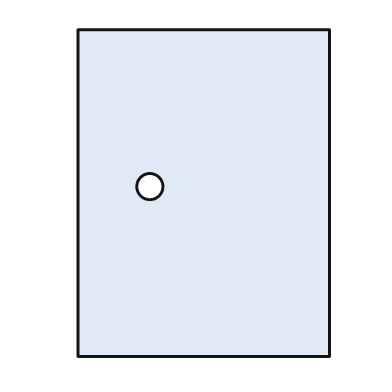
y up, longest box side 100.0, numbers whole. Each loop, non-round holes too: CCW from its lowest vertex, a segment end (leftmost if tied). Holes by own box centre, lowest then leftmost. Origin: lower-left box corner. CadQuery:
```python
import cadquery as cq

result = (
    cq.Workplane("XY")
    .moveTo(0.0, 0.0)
    .lineTo(77.0, 0.0)
    .lineTo(77.0, 100.0)
    .lineTo(0.0, 100.0)
    .close()
    .moveTo(22.0, 52.0)
    .circle(4.0)
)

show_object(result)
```